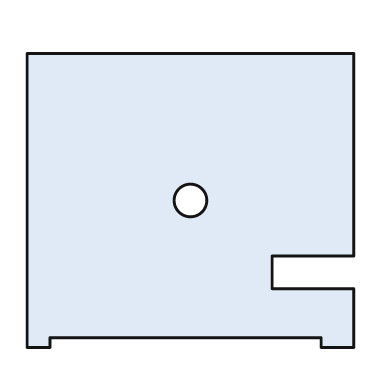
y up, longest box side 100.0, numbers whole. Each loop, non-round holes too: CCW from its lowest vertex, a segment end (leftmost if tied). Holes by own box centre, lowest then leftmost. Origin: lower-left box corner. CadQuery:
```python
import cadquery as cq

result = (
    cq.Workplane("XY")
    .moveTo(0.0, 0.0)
    .lineTo(7.0, 0.0)
    .lineTo(7.0, 3.0)
    .lineTo(90.0, 3.0)
    .lineTo(90.0, 0.0)
    .lineTo(100.0, 0.0)
    .lineTo(100.0, 18.0)
    .lineTo(75.0, 18.0)
    .lineTo(75.0, 28.0)
    .lineTo(100.0, 28.0)
    .lineTo(100.0, 90.0)
    .lineTo(0.0, 90.0)
    .close()
    .moveTo(50.0, 45.0)
    .circle(5.0)
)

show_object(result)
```